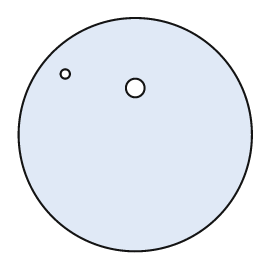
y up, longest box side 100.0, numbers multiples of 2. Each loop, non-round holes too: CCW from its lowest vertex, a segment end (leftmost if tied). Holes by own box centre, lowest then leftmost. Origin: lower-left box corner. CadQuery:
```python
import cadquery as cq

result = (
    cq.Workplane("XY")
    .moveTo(50.0, 50.0)
    .circle(50.0)
    .moveTo(50.0, 70.0)
    .circle(4.0)
    .moveTo(20.0, 76.0)
    .circle(2.0)
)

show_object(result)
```